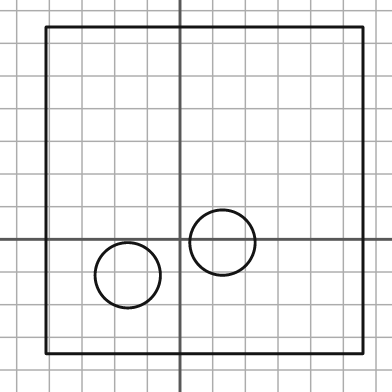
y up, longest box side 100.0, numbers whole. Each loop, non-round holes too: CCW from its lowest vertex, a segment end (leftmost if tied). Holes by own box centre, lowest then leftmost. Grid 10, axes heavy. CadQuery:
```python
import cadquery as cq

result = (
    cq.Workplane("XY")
    .moveTo(-41.0, -35.0)
    .lineTo(56.0, -35.0)
    .lineTo(56.0, 65.0)
    .lineTo(-41.0, 65.0)
    .close()
    .moveTo(-16.0, -11.0)
    .circle(10.0)
    .moveTo(13.0, -1.0)
    .circle(10.0)
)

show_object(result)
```